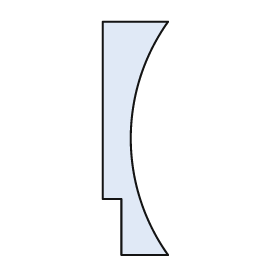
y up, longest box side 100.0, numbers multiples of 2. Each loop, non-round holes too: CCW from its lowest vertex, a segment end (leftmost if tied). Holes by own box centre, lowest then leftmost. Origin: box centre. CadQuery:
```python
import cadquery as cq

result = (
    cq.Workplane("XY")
    .moveTo(-6.0, -50.0)
    .lineTo(14.0, -50.0)
    .threePointArc((-2.0, 0.0), (14.0, 50.0))
    .lineTo(-14.0, 50.0)
    .lineTo(-14.0, -26.0)
    .lineTo(-6.0, -26.0)
    .close()
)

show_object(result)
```